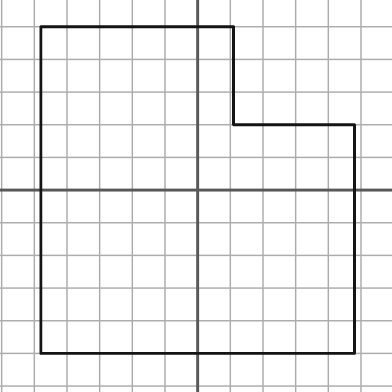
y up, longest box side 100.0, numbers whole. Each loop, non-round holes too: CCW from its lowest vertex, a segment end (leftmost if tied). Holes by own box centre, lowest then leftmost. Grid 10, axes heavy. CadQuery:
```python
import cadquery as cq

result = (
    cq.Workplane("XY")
    .moveTo(-48.0, -50.0)
    .lineTo(48.0, -50.0)
    .lineTo(48.0, 20.0)
    .lineTo(11.0, 20.0)
    .lineTo(11.0, 50.0)
    .lineTo(-48.0, 50.0)
    .close()
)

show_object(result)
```